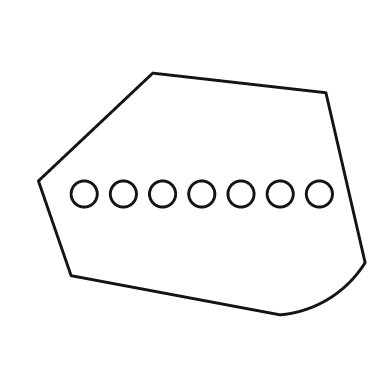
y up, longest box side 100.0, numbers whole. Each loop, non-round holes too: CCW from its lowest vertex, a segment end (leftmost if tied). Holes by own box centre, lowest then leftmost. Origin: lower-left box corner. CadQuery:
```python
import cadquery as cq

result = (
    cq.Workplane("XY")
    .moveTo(74.0, 0.0)
    .threePointArc((89.0, 5.0), (100.0, 16.0))
    .lineTo(88.0, 68.0)
    .lineTo(35.0, 74.0)
    .lineTo(0.0, 41.0)
    .lineTo(10.0, 12.0)
    .close()
    .moveTo(14.0, 37.0)
    .circle(4.0)
    .moveTo(26.0, 37.0)
    .circle(4.0)
    .moveTo(38.0, 37.0)
    .circle(4.0)
    .moveTo(50.0, 37.0)
    .circle(4.0)
    .moveTo(62.0, 37.0)
    .circle(4.0)
    .moveTo(74.0, 37.0)
    .circle(4.0)
    .moveTo(86.0, 37.0)
    .circle(4.0)
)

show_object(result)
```